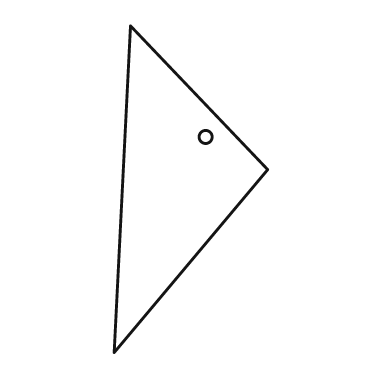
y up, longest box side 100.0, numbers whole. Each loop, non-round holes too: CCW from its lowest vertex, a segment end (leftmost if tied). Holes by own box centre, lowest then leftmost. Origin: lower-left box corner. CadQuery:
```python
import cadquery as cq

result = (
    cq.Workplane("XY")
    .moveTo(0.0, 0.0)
    .lineTo(47.0, 56.0)
    .lineTo(5.0, 100.0)
    .close()
    .moveTo(28.0, 66.0)
    .circle(2.0)
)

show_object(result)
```